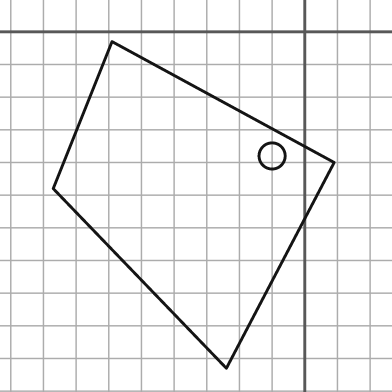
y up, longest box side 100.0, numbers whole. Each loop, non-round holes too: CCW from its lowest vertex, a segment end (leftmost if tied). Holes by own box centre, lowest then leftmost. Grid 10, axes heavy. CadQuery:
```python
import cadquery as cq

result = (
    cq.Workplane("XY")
    .moveTo(-24.0, -103.0)
    .lineTo(9.0, -40.0)
    .lineTo(-59.0, -3.0)
    .lineTo(-77.0, -48.0)
    .close()
    .moveTo(-10.0, -38.0)
    .circle(4.0)
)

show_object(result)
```